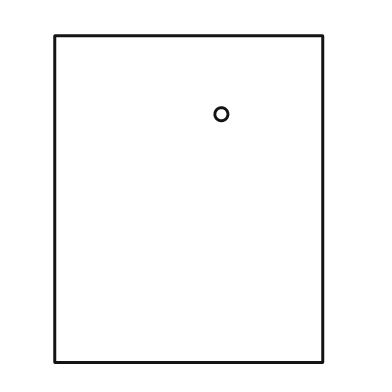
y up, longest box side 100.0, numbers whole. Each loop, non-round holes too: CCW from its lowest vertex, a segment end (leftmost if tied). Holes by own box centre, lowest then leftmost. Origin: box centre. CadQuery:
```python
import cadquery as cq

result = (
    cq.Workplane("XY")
    .moveTo(-41.0, -50.0)
    .lineTo(41.0, -50.0)
    .lineTo(41.0, 50.0)
    .lineTo(-41.0, 50.0)
    .close()
    .moveTo(10.0, 26.0)
    .circle(2.0)
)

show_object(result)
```